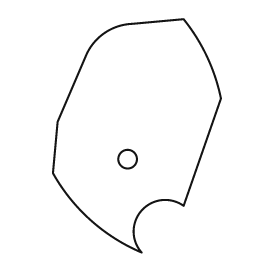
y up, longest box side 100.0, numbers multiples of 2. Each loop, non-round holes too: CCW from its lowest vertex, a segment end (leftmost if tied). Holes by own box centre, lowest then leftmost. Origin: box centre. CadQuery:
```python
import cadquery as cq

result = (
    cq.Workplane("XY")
    .moveTo(2.0, -50.0)
    .threePointArc((2.0, -32.0), (20.0, -30.0))
    .lineTo(36.0, 16.0)
    .threePointArc((30.0, 34.0), (20.0, 50.0))
    .lineTo(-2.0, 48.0)
    .threePointArc((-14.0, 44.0), (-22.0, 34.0))
    .lineTo(-34.0, 6.0)
    .lineTo(-36.0, -16.0)
    .threePointArc((-20.0, -36.0), (2.0, -50.0))
    .close()
    .moveTo(-4.0, -10.0)
    .circle(4.0)
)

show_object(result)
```